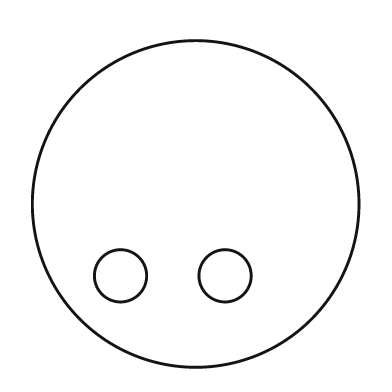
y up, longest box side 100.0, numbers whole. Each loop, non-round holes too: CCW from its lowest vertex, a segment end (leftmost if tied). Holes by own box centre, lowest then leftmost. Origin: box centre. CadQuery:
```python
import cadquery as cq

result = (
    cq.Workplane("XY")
    .moveTo(0.0, 0.0)
    .circle(50.0)
    .moveTo(-23.0, -22.0)
    .circle(8.0)
    .moveTo(9.0, -22.0)
    .circle(8.0)
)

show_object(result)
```